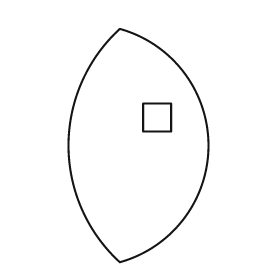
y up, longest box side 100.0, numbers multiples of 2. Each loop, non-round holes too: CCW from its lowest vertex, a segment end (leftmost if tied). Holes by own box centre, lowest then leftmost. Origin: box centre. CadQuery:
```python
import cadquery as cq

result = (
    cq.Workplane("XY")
    .moveTo(-8.0, -50.0)
    .threePointArc((30.0, 0.0), (-8.0, 50.0))
    .threePointArc((-30.0, 0.0), (-8.0, -50.0))
    .close()
    .moveTo(2.0, 6.0)
    .lineTo(14.0, 6.0)
    .lineTo(14.0, 18.0)
    .lineTo(2.0, 18.0)
    .close()
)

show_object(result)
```